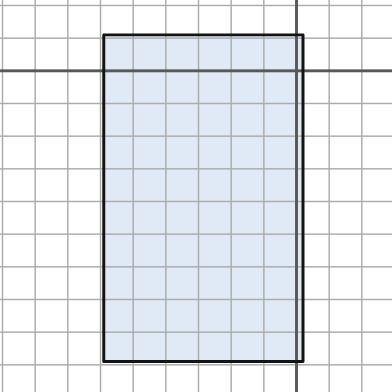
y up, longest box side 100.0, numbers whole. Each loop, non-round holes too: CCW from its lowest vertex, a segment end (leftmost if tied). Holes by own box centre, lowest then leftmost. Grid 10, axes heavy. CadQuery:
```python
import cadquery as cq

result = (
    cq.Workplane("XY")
    .moveTo(-59.0, -89.0)
    .lineTo(2.0, -89.0)
    .lineTo(2.0, 11.0)
    .lineTo(-59.0, 11.0)
    .close()
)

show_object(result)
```